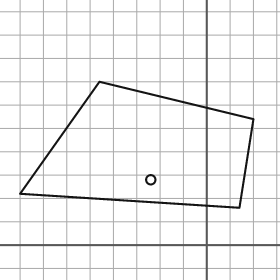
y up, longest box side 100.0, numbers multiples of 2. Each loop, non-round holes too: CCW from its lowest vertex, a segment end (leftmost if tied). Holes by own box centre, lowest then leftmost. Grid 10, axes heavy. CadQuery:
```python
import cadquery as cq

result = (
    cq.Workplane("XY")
    .moveTo(14.0, 16.0)
    .lineTo(20.0, 54.0)
    .lineTo(-46.0, 70.0)
    .lineTo(-80.0, 22.0)
    .close()
    .moveTo(-24.0, 28.0)
    .circle(2.0)
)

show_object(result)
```